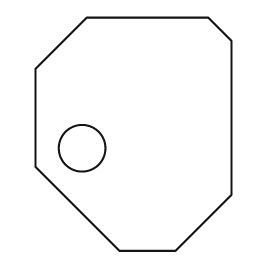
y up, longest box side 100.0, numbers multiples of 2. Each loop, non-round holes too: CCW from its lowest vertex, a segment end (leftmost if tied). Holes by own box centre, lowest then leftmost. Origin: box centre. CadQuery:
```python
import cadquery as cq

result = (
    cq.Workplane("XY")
    .moveTo(-6.0, -50.0)
    .lineTo(18.0, -50.0)
    .lineTo(42.0, -26.0)
    .lineTo(42.0, 40.0)
    .lineTo(32.0, 50.0)
    .lineTo(-20.0, 50.0)
    .lineTo(-42.0, 28.0)
    .lineTo(-42.0, -14.0)
    .close()
    .moveTo(-22.0, -6.0)
    .circle(10.0)
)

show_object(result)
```